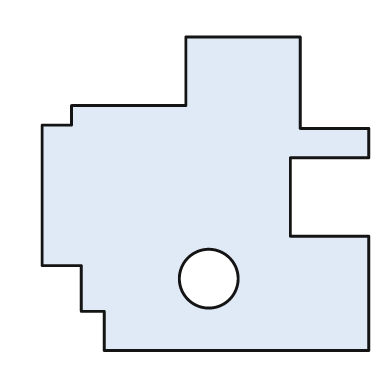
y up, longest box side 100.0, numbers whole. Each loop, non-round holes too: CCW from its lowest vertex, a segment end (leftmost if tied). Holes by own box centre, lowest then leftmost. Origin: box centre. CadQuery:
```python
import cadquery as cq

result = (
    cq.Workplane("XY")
    .moveTo(-31.0, -48.0)
    .lineTo(50.0, -48.0)
    .lineTo(50.0, -13.0)
    .lineTo(26.0, -13.0)
    .lineTo(26.0, 11.0)
    .lineTo(50.0, 11.0)
    .lineTo(50.0, 20.0)
    .lineTo(29.0, 20.0)
    .lineTo(29.0, 48.0)
    .lineTo(-6.0, 48.0)
    .lineTo(-6.0, 27.0)
    .lineTo(-41.0, 27.0)
    .lineTo(-41.0, 21.0)
    .lineTo(-50.0, 21.0)
    .lineTo(-50.0, -22.0)
    .lineTo(-38.0, -22.0)
    .lineTo(-38.0, -36.0)
    .lineTo(-31.0, -36.0)
    .close()
    .moveTo(1.0, -26.0)
    .circle(9.0)
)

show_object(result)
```